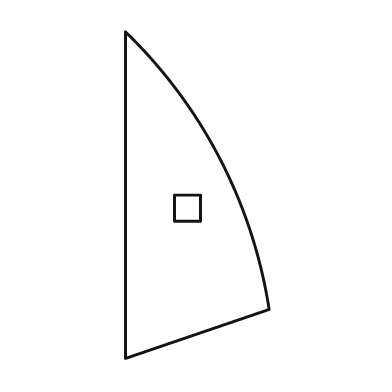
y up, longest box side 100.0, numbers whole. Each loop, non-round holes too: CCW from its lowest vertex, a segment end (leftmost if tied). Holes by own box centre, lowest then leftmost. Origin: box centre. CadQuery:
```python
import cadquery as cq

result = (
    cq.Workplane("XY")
    .moveTo(-22.0, -50.0)
    .lineTo(22.0, -35.0)
    .threePointArc((7.0, 11.0), (-22.0, 50.0))
    .close()
    .moveTo(-7.0, -8.0)
    .lineTo(1.0, -8.0)
    .lineTo(1.0, 0.0)
    .lineTo(-7.0, 0.0)
    .close()
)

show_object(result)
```